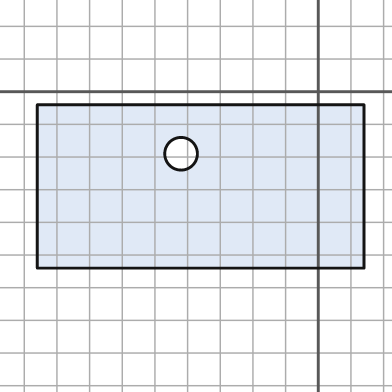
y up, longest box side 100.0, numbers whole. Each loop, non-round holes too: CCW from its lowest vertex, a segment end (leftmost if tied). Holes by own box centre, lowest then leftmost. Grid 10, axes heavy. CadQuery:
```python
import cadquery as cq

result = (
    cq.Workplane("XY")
    .moveTo(-86.0, -54.0)
    .lineTo(14.0, -54.0)
    .lineTo(14.0, -4.0)
    .lineTo(-86.0, -4.0)
    .close()
    .moveTo(-42.0, -19.0)
    .circle(5.0)
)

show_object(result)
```